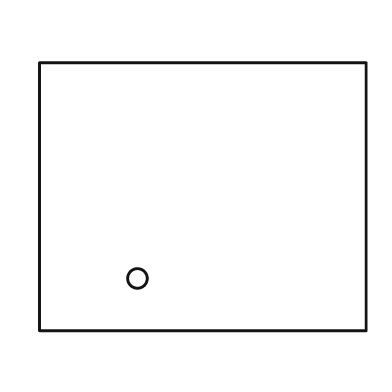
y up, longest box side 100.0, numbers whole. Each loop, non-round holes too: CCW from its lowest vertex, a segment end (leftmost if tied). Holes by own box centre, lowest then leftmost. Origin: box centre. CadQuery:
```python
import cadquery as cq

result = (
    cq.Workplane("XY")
    .moveTo(-50.0, -41.0)
    .lineTo(50.0, -41.0)
    .lineTo(50.0, 41.0)
    .lineTo(-50.0, 41.0)
    .close()
    .moveTo(-20.0, -25.0)
    .circle(3.0)
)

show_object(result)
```